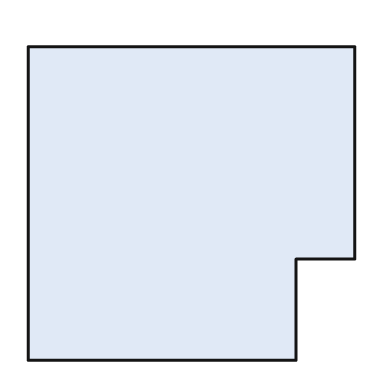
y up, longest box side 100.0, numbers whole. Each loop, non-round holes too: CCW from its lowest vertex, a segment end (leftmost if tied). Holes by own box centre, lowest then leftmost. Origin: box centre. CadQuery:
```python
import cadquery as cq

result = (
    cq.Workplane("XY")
    .moveTo(-50.0, -48.0)
    .lineTo(32.0, -48.0)
    .lineTo(32.0, -17.0)
    .lineTo(50.0, -17.0)
    .lineTo(50.0, 48.0)
    .lineTo(-50.0, 48.0)
    .close()
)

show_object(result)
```